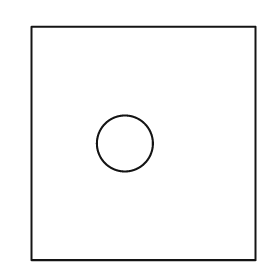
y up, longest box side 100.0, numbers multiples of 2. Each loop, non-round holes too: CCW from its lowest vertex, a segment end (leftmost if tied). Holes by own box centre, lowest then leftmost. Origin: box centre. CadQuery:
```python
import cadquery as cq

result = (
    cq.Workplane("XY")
    .moveTo(-48.0, -50.0)
    .lineTo(48.0, -50.0)
    .lineTo(48.0, 50.0)
    .lineTo(-48.0, 50.0)
    .close()
    .moveTo(-8.0, 0.0)
    .circle(12.0)
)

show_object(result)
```